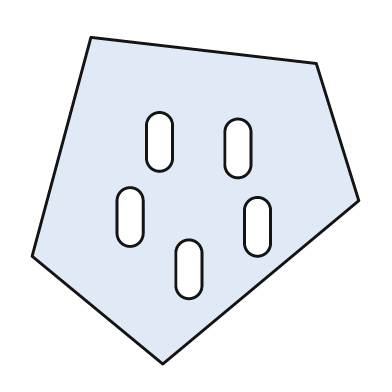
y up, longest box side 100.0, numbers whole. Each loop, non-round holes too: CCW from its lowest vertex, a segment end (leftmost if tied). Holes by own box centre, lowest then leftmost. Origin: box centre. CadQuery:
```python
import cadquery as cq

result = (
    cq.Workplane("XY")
    .moveTo(-10.0, -50.0)
    .lineTo(50.0, 0.0)
    .lineTo(37.0, 42.0)
    .lineTo(-32.0, 50.0)
    .lineTo(-50.0, -17.0)
    .close()
    .moveTo(-6.0, -26.0)
    .threePointArc((-2.0, -30.0), (2.0, -26.0))
    .lineTo(2.0, -16.0)
    .threePointArc((-2.0, -12.0), (-6.0, -16.0))
    .close()
    .moveTo(15.0, -13.0)
    .threePointArc((19.0, -17.0), (23.0, -13.0))
    .lineTo(23.0, -3.0)
    .threePointArc((19.0, 1.0), (15.0, -3.0))
    .close()
    .moveTo(-24.0, -10.0)
    .threePointArc((-20.0, -14.0), (-16.0, -10.0))
    .lineTo(-16.0, 0.0)
    .threePointArc((-20.0, 4.0), (-24.0, 0.0))
    .close()
    .moveTo(9.0, 11.0)
    .threePointArc((13.0, 7.0), (17.0, 11.0))
    .lineTo(17.0, 21.0)
    .threePointArc((13.0, 25.0), (9.0, 21.0))
    .close()
    .moveTo(-15.0, 13.0)
    .threePointArc((-11.0, 9.0), (-7.0, 13.0))
    .lineTo(-7.0, 23.0)
    .threePointArc((-11.0, 27.0), (-15.0, 23.0))
    .close()
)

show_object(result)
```